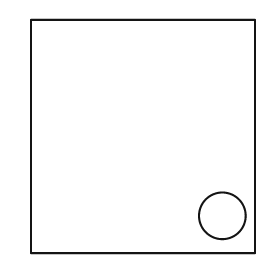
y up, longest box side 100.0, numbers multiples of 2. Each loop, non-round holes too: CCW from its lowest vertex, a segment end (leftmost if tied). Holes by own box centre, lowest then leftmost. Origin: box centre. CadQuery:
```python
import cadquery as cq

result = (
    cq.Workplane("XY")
    .moveTo(-48.0, -50.0)
    .lineTo(48.0, -50.0)
    .lineTo(48.0, 50.0)
    .lineTo(-48.0, 50.0)
    .close()
    .moveTo(34.0, -34.0)
    .circle(10.0)
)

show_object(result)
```